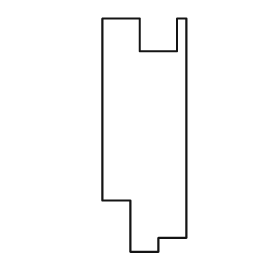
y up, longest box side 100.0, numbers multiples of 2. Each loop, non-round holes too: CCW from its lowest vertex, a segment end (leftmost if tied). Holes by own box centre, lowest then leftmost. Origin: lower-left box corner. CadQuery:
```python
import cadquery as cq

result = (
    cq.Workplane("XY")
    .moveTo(12.0, 0.0)
    .lineTo(24.0, 0.0)
    .lineTo(24.0, 6.0)
    .lineTo(36.0, 6.0)
    .lineTo(36.0, 100.0)
    .lineTo(32.0, 100.0)
    .lineTo(32.0, 86.0)
    .lineTo(16.0, 86.0)
    .lineTo(16.0, 100.0)
    .lineTo(0.0, 100.0)
    .lineTo(0.0, 22.0)
    .lineTo(12.0, 22.0)
    .close()
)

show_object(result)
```